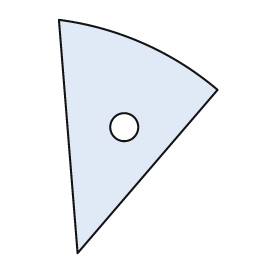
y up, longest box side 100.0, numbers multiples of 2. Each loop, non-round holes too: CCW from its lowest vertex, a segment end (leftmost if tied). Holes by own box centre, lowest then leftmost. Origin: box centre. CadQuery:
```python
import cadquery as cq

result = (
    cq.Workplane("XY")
    .moveTo(-26.0, -50.0)
    .lineTo(34.0, 20.0)
    .threePointArc((2.0, 40.0), (-34.0, 50.0))
    .close()
    .moveTo(-6.0, 4.0)
    .circle(6.0)
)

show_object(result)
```